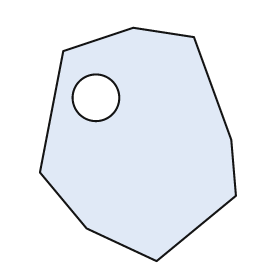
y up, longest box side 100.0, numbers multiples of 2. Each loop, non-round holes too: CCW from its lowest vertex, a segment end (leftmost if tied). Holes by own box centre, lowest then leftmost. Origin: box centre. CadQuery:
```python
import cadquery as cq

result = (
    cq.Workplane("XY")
    .moveTo(8.0, -50.0)
    .lineTo(42.0, -22.0)
    .lineTo(40.0, 2.0)
    .lineTo(24.0, 46.0)
    .lineTo(-2.0, 50.0)
    .lineTo(-32.0, 40.0)
    .lineTo(-42.0, -12.0)
    .lineTo(-22.0, -36.0)
    .close()
    .moveTo(-18.0, 20.0)
    .circle(10.0)
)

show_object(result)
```